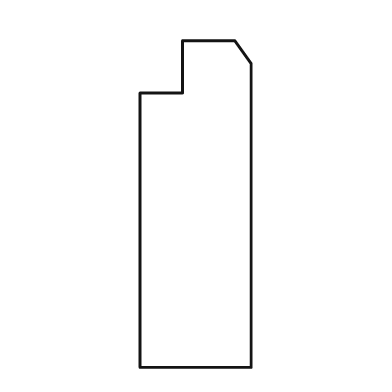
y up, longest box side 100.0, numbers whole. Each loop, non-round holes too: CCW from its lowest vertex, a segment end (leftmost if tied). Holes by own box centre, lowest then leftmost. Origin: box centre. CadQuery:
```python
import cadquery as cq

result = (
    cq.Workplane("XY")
    .moveTo(-17.0, -50.0)
    .lineTo(17.0, -50.0)
    .lineTo(17.0, 43.0)
    .lineTo(12.0, 50.0)
    .lineTo(-4.0, 50.0)
    .lineTo(-4.0, 34.0)
    .lineTo(-17.0, 34.0)
    .close()
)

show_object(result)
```